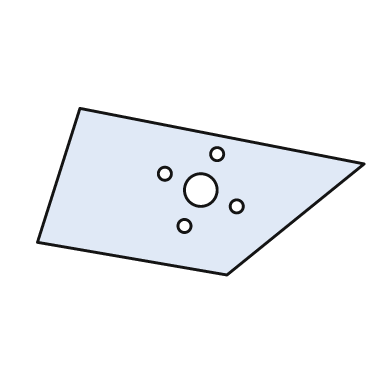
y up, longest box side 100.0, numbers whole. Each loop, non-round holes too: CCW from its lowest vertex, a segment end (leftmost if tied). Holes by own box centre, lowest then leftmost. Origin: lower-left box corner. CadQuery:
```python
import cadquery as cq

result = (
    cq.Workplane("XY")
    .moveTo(58.0, 0.0)
    .lineTo(100.0, 34.0)
    .lineTo(13.0, 51.0)
    .lineTo(0.0, 10.0)
    .close()
    .moveTo(45.0, 15.0)
    .circle(2.0)
    .moveTo(61.0, 21.0)
    .circle(2.0)
    .moveTo(50.0, 26.0)
    .circle(5.0)
    .moveTo(39.0, 31.0)
    .circle(2.0)
    .moveTo(55.0, 37.0)
    .circle(2.0)
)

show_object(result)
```